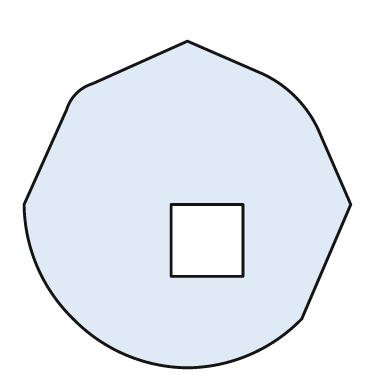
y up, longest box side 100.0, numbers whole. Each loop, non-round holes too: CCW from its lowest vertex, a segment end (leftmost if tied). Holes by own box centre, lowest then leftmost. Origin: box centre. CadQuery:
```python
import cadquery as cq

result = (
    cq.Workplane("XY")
    .moveTo(0.0, -50.0)
    .threePointArc((19.0, -46.0), (35.0, -35.0))
    .lineTo(50.0, 0.0)
    .lineTo(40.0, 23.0)
    .threePointArc((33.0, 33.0), (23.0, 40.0))
    .lineTo(0.0, 50.0)
    .lineTo(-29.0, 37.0)
    .threePointArc((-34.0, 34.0), (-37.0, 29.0))
    .lineTo(-50.0, 0.0)
    .threePointArc((-46.0, -19.0), (-35.0, -35.0))
    .threePointArc((-19.0, -46.0), (0.0, -50.0))
    .close()
    .moveTo(-5.0, -22.0)
    .lineTo(17.0, -22.0)
    .lineTo(17.0, 0.0)
    .lineTo(-5.0, 0.0)
    .close()
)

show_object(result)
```